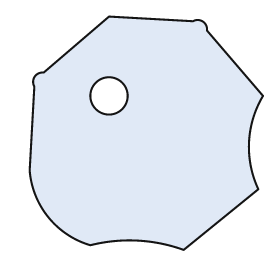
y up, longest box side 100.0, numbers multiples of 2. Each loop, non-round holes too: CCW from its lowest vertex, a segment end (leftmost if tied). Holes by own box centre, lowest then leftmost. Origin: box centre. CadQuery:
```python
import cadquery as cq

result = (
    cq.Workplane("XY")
    .moveTo(16.0, -50.0)
    .lineTo(48.0, -24.0)
    .threePointArc((44.0, -4.0), (50.0, 16.0))
    .lineTo(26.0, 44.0)
    .threePointArc((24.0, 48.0), (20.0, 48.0))
    .lineTo(-16.0, 50.0)
    .lineTo(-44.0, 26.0)
    .threePointArc((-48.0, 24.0), (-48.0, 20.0))
    .lineTo(-50.0, -16.0)
    .threePointArc((-42.0, -36.0), (-24.0, -48.0))
    .threePointArc((-4.0, -46.0), (16.0, -50.0))
    .close()
    .moveTo(-16.0, 16.0)
    .circle(8.0)
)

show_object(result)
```